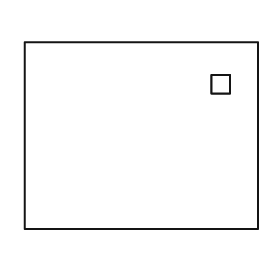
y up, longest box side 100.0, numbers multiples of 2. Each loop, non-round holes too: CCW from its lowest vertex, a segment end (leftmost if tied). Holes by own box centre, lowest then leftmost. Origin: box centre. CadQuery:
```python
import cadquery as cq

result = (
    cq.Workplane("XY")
    .moveTo(-50.0, -40.0)
    .lineTo(50.0, -40.0)
    .lineTo(50.0, 40.0)
    .lineTo(-50.0, 40.0)
    .close()
    .moveTo(30.0, 18.0)
    .lineTo(38.0, 18.0)
    .lineTo(38.0, 26.0)
    .lineTo(30.0, 26.0)
    .close()
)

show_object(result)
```